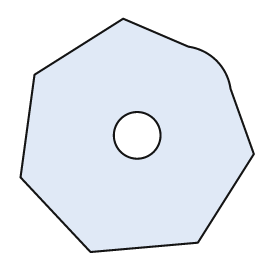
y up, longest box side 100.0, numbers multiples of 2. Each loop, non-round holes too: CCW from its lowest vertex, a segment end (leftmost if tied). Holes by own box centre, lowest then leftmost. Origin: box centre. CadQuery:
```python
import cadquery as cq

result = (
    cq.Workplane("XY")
    .moveTo(-20.0, -50.0)
    .lineTo(26.0, -46.0)
    .lineTo(50.0, -8.0)
    .lineTo(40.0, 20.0)
    .threePointArc((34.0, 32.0), (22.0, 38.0))
    .lineTo(-6.0, 50.0)
    .lineTo(-44.0, 26.0)
    .lineTo(-50.0, -18.0)
    .close()
    .moveTo(0.0, 0.0)
    .circle(10.0)
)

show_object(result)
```